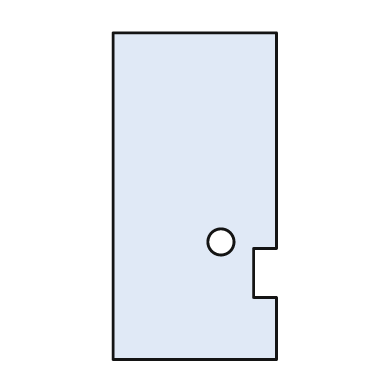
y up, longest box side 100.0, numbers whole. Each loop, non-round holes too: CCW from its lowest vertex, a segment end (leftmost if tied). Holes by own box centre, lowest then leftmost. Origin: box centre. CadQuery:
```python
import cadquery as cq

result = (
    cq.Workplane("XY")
    .moveTo(-25.0, -50.0)
    .lineTo(25.0, -50.0)
    .lineTo(25.0, -31.0)
    .lineTo(18.0, -31.0)
    .lineTo(18.0, -16.0)
    .lineTo(25.0, -16.0)
    .lineTo(25.0, 50.0)
    .lineTo(-25.0, 50.0)
    .close()
    .moveTo(8.0, -14.0)
    .circle(4.0)
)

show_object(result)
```